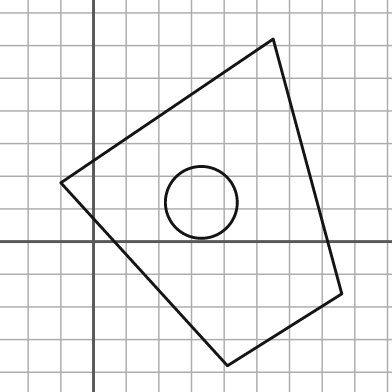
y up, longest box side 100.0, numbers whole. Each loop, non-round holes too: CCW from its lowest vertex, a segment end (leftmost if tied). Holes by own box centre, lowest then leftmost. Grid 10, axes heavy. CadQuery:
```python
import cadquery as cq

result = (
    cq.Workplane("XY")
    .moveTo(41.0, -38.0)
    .lineTo(76.0, -16.0)
    .lineTo(55.0, 62.0)
    .lineTo(-10.0, 18.0)
    .close()
    .moveTo(33.0, 12.0)
    .circle(11.0)
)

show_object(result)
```